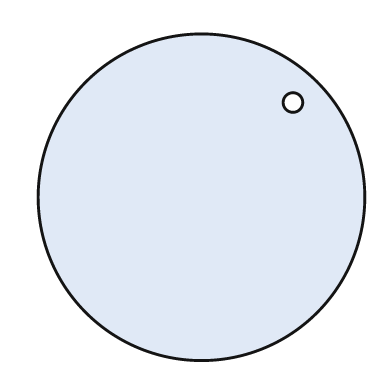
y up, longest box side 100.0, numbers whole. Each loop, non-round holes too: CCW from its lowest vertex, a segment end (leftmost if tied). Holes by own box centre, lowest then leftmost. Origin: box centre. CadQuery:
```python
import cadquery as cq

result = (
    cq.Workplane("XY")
    .moveTo(0.0, 0.0)
    .circle(50.0)
    .moveTo(28.0, 29.0)
    .circle(3.0)
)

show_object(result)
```